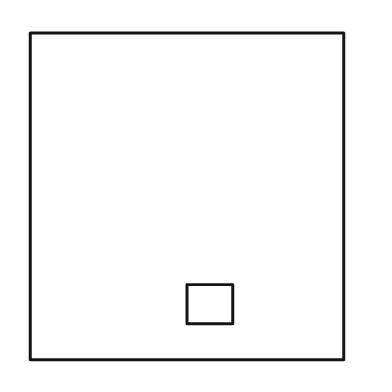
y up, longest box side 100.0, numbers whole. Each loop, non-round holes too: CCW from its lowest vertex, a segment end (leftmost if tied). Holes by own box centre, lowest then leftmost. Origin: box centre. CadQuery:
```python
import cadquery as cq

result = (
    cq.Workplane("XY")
    .moveTo(-48.0, -50.0)
    .lineTo(48.0, -50.0)
    .lineTo(48.0, 50.0)
    .lineTo(-48.0, 50.0)
    .close()
    .moveTo(0.0, -39.0)
    .lineTo(14.0, -39.0)
    .lineTo(14.0, -27.0)
    .lineTo(0.0, -27.0)
    .close()
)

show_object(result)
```